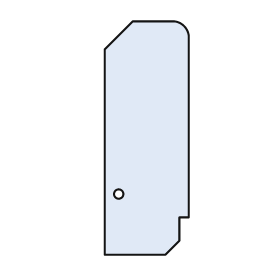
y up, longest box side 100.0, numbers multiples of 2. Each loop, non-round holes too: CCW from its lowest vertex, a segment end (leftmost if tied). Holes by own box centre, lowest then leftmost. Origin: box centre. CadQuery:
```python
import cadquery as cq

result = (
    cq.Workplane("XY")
    .moveTo(-18.0, -50.0)
    .lineTo(8.0, -50.0)
    .lineTo(14.0, -44.0)
    .lineTo(14.0, -34.0)
    .lineTo(18.0, -34.0)
    .lineTo(18.0, 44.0)
    .threePointArc((16.0, 48.0), (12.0, 50.0))
    .lineTo(-6.0, 50.0)
    .lineTo(-18.0, 38.0)
    .close()
    .moveTo(-12.0, -24.0)
    .circle(2.0)
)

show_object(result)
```